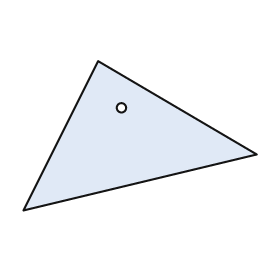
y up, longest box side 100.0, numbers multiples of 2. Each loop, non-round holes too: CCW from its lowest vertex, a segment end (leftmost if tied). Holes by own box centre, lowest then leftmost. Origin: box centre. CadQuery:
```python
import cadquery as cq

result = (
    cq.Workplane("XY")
    .moveTo(-50.0, -32.0)
    .lineTo(50.0, -8.0)
    .lineTo(-18.0, 32.0)
    .close()
    .moveTo(-8.0, 12.0)
    .circle(2.0)
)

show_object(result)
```